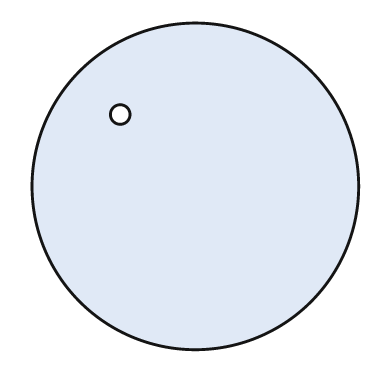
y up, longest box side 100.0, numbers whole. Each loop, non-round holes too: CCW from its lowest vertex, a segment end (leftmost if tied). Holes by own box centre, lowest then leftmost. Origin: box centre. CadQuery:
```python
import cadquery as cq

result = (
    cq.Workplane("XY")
    .moveTo(0.0, 0.0)
    .circle(50.0)
    .moveTo(-23.0, 22.0)
    .circle(3.0)
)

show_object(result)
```